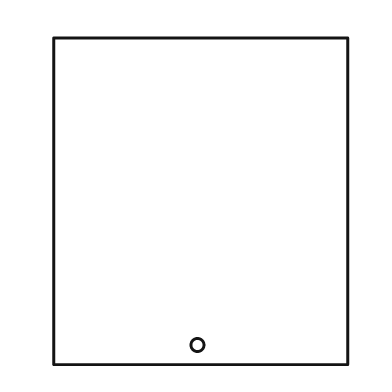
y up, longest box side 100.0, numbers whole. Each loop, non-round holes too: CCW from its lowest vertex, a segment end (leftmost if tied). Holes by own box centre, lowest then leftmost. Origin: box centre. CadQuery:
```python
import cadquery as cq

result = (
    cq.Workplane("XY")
    .moveTo(-45.0, -50.0)
    .lineTo(45.0, -50.0)
    .lineTo(45.0, 50.0)
    .lineTo(-45.0, 50.0)
    .close()
    .moveTo(-1.0, -44.0)
    .circle(2.0)
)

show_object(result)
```